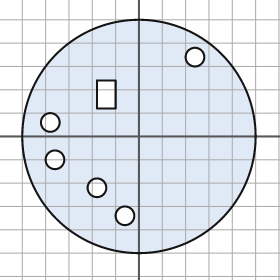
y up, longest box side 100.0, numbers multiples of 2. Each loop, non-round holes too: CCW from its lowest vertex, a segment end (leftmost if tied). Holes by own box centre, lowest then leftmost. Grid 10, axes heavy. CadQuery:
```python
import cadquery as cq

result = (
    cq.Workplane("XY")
    .moveTo(0.0, 0.0)
    .circle(50.0)
    .moveTo(-6.0, -34.0)
    .circle(4.0)
    .moveTo(-18.0, -22.0)
    .circle(4.0)
    .moveTo(-36.0, -10.0)
    .circle(4.0)
    .moveTo(-38.0, 6.0)
    .circle(4.0)
    .moveTo(-18.0, 12.0)
    .lineTo(-10.0, 12.0)
    .lineTo(-10.0, 24.0)
    .lineTo(-18.0, 24.0)
    .close()
    .moveTo(24.0, 34.0)
    .circle(4.0)
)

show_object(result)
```